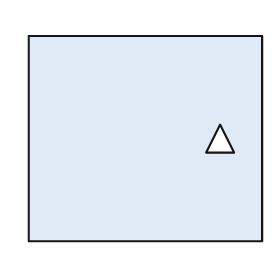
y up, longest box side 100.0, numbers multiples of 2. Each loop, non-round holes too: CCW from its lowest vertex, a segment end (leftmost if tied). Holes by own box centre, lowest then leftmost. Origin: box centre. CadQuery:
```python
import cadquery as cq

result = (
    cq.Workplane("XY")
    .moveTo(-50.0, -44.0)
    .lineTo(50.0, -44.0)
    .lineTo(50.0, 44.0)
    .lineTo(-50.0, 44.0)
    .close()
    .moveTo(26.0, -6.0)
    .lineTo(38.0, -6.0)
    .lineTo(32.0, 6.0)
    .close()
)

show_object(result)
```